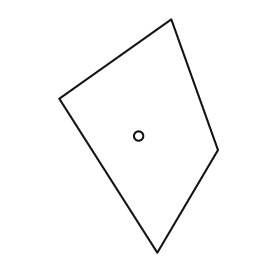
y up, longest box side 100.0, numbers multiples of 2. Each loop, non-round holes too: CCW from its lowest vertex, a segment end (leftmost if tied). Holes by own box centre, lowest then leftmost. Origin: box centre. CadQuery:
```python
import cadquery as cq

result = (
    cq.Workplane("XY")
    .moveTo(8.0, -50.0)
    .lineTo(34.0, -6.0)
    .lineTo(14.0, 50.0)
    .lineTo(-34.0, 16.0)
    .close()
    .moveTo(0.0, 0.0)
    .circle(2.0)
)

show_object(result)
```